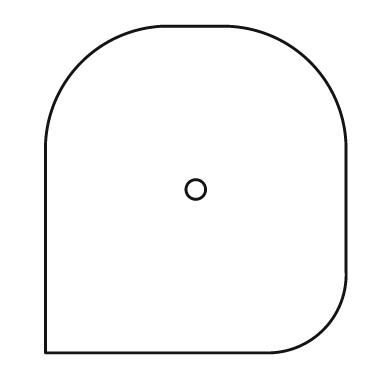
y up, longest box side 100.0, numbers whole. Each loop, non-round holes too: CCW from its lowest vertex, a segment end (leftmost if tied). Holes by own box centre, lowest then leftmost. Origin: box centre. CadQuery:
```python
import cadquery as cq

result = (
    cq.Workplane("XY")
    .moveTo(-46.0, -50.0)
    .lineTo(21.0, -50.0)
    .threePointArc((39.0, -43.0), (46.0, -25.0))
    .lineTo(46.0, 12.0)
    .threePointArc((35.0, 39.0), (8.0, 50.0))
    .lineTo(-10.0, 50.0)
    .threePointArc((-35.0, 39.0), (-46.0, 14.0))
    .close()
    .moveTo(0.0, 0.0)
    .circle(3.0)
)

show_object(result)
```